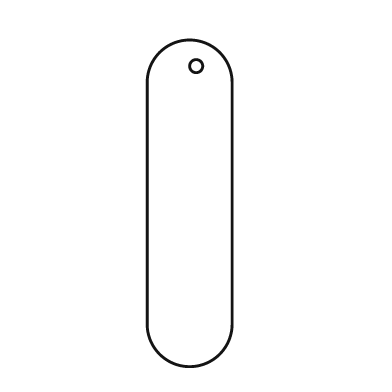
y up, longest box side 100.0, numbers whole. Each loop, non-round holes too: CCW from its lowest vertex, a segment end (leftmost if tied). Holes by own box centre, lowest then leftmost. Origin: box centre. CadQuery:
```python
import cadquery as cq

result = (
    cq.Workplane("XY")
    .moveTo(-13.0, -37.0)
    .threePointArc((0.0, -50.0), (13.0, -37.0))
    .lineTo(13.0, 37.0)
    .threePointArc((0.0, 50.0), (-13.0, 37.0))
    .close()
    .moveTo(2.0, 42.0)
    .circle(2.0)
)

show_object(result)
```